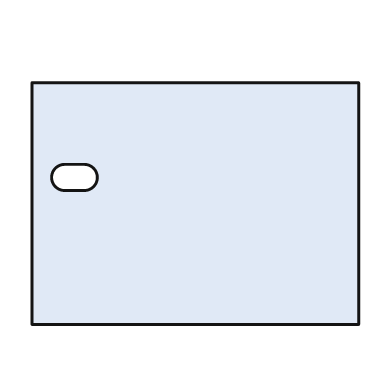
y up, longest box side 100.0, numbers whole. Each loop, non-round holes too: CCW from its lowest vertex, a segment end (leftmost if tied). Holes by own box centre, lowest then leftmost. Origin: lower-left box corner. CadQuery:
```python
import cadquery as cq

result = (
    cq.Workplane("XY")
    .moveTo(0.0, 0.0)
    .lineTo(100.0, 0.0)
    .lineTo(100.0, 74.0)
    .lineTo(0.0, 74.0)
    .close()
    .moveTo(10.0, 41.0)
    .lineTo(16.0, 41.0)
    .threePointArc((20.0, 45.0), (16.0, 49.0))
    .lineTo(10.0, 49.0)
    .threePointArc((6.0, 45.0), (10.0, 41.0))
    .close()
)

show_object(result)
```